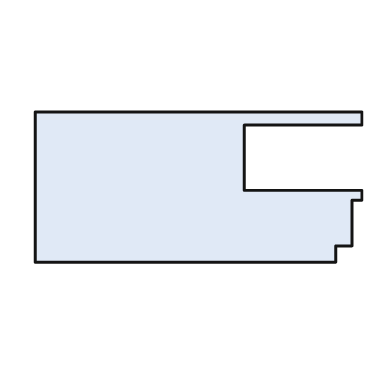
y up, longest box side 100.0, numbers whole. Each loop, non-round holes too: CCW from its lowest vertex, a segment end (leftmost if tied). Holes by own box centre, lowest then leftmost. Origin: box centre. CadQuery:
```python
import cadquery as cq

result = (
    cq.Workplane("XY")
    .moveTo(-50.0, -23.0)
    .lineTo(42.0, -23.0)
    .lineTo(42.0, -18.0)
    .lineTo(47.0, -18.0)
    .lineTo(47.0, -4.0)
    .lineTo(50.0, -4.0)
    .lineTo(50.0, -1.0)
    .lineTo(14.0, -1.0)
    .lineTo(14.0, 19.0)
    .lineTo(50.0, 19.0)
    .lineTo(50.0, 23.0)
    .lineTo(-50.0, 23.0)
    .close()
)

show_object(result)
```